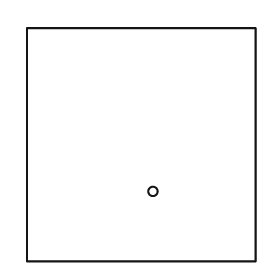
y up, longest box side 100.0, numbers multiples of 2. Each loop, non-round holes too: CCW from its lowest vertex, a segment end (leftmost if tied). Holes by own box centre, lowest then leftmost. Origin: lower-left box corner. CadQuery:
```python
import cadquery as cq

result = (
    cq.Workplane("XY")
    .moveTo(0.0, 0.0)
    .lineTo(98.0, 0.0)
    .lineTo(98.0, 100.0)
    .lineTo(0.0, 100.0)
    .close()
    .moveTo(54.0, 30.0)
    .circle(2.0)
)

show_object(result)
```